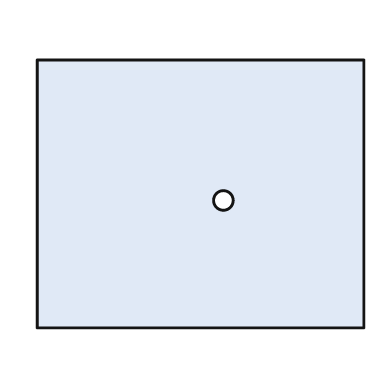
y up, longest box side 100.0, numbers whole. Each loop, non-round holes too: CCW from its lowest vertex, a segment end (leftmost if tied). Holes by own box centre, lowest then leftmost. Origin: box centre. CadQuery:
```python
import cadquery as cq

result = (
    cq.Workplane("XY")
    .moveTo(-50.0, -41.0)
    .lineTo(50.0, -41.0)
    .lineTo(50.0, 41.0)
    .lineTo(-50.0, 41.0)
    .close()
    .moveTo(7.0, -2.0)
    .circle(3.0)
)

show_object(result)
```